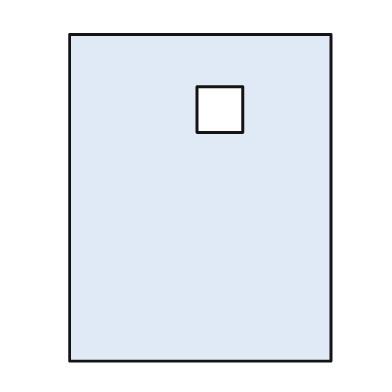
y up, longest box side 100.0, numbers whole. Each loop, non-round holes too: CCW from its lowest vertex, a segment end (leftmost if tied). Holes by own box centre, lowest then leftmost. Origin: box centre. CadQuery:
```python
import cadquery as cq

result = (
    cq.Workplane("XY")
    .moveTo(-40.0, -50.0)
    .lineTo(40.0, -50.0)
    .lineTo(40.0, 50.0)
    .lineTo(-40.0, 50.0)
    .close()
    .moveTo(-1.0, 20.0)
    .lineTo(13.0, 20.0)
    .lineTo(13.0, 34.0)
    .lineTo(-1.0, 34.0)
    .close()
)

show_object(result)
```